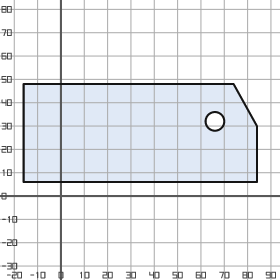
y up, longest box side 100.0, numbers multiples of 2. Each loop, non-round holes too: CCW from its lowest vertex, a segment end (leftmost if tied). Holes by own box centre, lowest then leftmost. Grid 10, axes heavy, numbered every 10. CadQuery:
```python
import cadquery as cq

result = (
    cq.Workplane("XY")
    .moveTo(-16.0, 6.0)
    .lineTo(84.0, 6.0)
    .lineTo(84.0, 30.0)
    .lineTo(74.0, 48.0)
    .lineTo(-16.0, 48.0)
    .close()
    .moveTo(66.0, 32.0)
    .circle(4.0)
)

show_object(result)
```